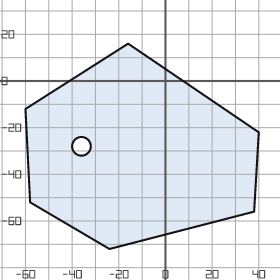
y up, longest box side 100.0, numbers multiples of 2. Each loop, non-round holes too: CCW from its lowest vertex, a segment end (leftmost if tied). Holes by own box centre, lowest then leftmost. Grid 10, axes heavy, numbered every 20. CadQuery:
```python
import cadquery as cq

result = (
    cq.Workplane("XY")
    .moveTo(-24.0, -72.0)
    .lineTo(38.0, -56.0)
    .lineTo(40.0, -22.0)
    .lineTo(-16.0, 16.0)
    .lineTo(-60.0, -12.0)
    .lineTo(-58.0, -52.0)
    .close()
    .moveTo(-36.0, -28.0)
    .circle(4.0)
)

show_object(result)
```